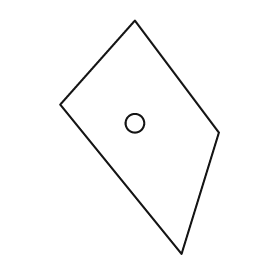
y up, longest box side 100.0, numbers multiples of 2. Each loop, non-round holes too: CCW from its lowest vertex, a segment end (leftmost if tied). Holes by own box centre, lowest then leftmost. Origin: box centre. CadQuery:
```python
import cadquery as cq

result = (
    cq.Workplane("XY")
    .moveTo(18.0, -50.0)
    .lineTo(34.0, 2.0)
    .lineTo(-2.0, 50.0)
    .lineTo(-34.0, 14.0)
    .close()
    .moveTo(-2.0, 6.0)
    .circle(4.0)
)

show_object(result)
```